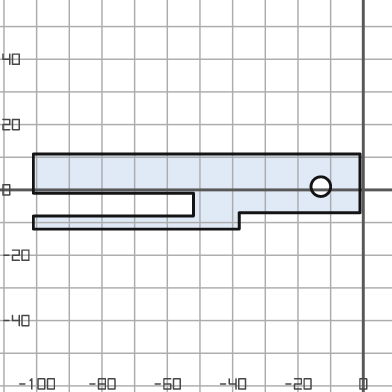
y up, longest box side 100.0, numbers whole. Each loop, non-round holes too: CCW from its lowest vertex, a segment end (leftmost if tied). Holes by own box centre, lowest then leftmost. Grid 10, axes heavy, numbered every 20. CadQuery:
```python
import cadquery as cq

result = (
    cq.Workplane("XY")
    .moveTo(-101.0, -12.0)
    .lineTo(-38.0, -12.0)
    .lineTo(-38.0, -7.0)
    .lineTo(-1.0, -7.0)
    .lineTo(-1.0, 11.0)
    .lineTo(-101.0, 11.0)
    .lineTo(-101.0, -1.0)
    .lineTo(-52.0, -1.0)
    .lineTo(-52.0, -8.0)
    .lineTo(-101.0, -8.0)
    .close()
    .moveTo(-13.0, 1.0)
    .circle(3.0)
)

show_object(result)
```